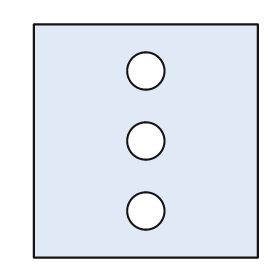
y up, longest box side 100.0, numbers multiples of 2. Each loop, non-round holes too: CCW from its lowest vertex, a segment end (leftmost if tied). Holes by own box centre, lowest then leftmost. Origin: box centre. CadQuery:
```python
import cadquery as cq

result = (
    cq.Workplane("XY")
    .moveTo(-48.0, -50.0)
    .lineTo(48.0, -50.0)
    .lineTo(48.0, 50.0)
    .lineTo(-48.0, 50.0)
    .close()
    .moveTo(0.0, -30.0)
    .circle(8.0)
    .moveTo(0.0, 0.0)
    .circle(8.0)
    .moveTo(0.0, 30.0)
    .circle(8.0)
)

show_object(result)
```